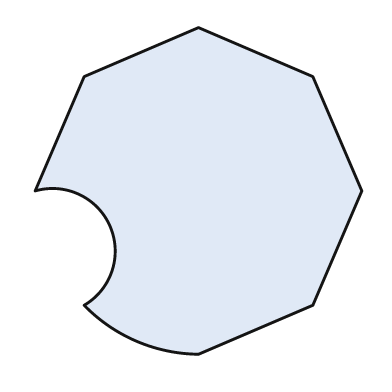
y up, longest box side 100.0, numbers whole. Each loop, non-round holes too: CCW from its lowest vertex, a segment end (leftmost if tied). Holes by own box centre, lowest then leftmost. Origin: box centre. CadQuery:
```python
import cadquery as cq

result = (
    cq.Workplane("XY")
    .moveTo(0.0, -50.0)
    .lineTo(35.0, -35.0)
    .lineTo(50.0, 0.0)
    .lineTo(35.0, 35.0)
    .lineTo(0.0, 50.0)
    .lineTo(-35.0, 35.0)
    .lineTo(-50.0, 0.0)
    .threePointArc((-27.0, -11.0), (-35.0, -35.0))
    .threePointArc((-19.0, -46.0), (0.0, -50.0))
    .close()
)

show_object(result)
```